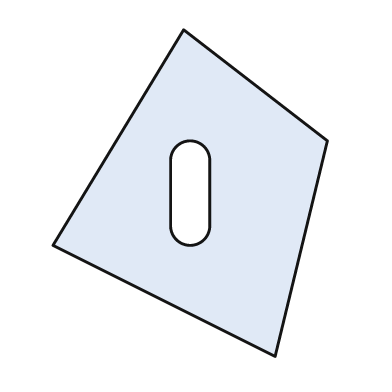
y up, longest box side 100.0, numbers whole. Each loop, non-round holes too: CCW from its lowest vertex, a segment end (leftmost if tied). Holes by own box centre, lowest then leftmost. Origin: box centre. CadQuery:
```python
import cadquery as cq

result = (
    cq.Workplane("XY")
    .moveTo(26.0, -50.0)
    .lineTo(42.0, 16.0)
    .lineTo(-2.0, 50.0)
    .lineTo(-42.0, -16.0)
    .close()
    .moveTo(-6.0, -10.0)
    .threePointArc((0.0, -16.0), (6.0, -10.0))
    .lineTo(6.0, 10.0)
    .threePointArc((0.0, 16.0), (-6.0, 10.0))
    .close()
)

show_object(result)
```